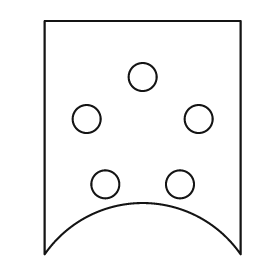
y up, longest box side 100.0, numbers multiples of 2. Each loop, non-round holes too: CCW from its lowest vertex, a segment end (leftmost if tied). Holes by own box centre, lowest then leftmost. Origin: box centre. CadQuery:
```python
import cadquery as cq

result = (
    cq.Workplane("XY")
    .moveTo(-42.0, -50.0)
    .threePointArc((0.0, -28.0), (42.0, -50.0))
    .lineTo(42.0, 50.0)
    .lineTo(-42.0, 50.0)
    .close()
    .moveTo(-16.0, -20.0)
    .circle(6.0)
    .moveTo(16.0, -20.0)
    .circle(6.0)
    .moveTo(-24.0, 8.0)
    .circle(6.0)
    .moveTo(24.0, 8.0)
    .circle(6.0)
    .moveTo(0.0, 26.0)
    .circle(6.0)
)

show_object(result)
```